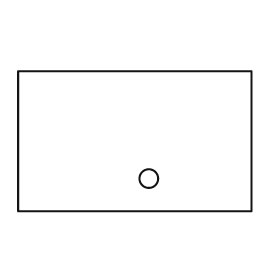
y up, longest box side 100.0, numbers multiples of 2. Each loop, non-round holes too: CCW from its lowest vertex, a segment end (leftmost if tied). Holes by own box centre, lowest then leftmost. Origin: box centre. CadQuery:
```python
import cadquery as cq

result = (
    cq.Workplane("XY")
    .moveTo(-50.0, -30.0)
    .lineTo(50.0, -30.0)
    .lineTo(50.0, 30.0)
    .lineTo(-50.0, 30.0)
    .close()
    .moveTo(6.0, -16.0)
    .circle(4.0)
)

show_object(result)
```